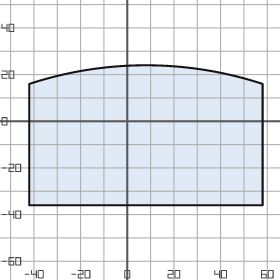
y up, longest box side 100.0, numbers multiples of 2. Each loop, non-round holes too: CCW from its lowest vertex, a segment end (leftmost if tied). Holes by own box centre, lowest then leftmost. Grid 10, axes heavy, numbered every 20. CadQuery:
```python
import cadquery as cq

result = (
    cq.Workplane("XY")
    .moveTo(-42.0, -36.0)
    .lineTo(58.0, -36.0)
    .lineTo(58.0, 16.0)
    .threePointArc((8.0, 24.0), (-42.0, 16.0))
    .close()
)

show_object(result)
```